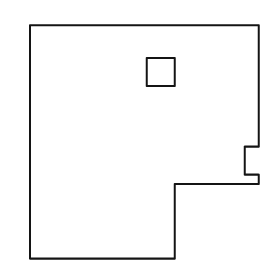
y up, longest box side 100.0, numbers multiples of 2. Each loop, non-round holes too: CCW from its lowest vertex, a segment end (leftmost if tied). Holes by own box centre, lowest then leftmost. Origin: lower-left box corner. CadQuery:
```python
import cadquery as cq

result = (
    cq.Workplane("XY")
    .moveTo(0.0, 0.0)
    .lineTo(62.0, 0.0)
    .lineTo(62.0, 32.0)
    .lineTo(98.0, 32.0)
    .lineTo(98.0, 36.0)
    .lineTo(92.0, 36.0)
    .lineTo(92.0, 48.0)
    .lineTo(98.0, 48.0)
    .lineTo(98.0, 100.0)
    .lineTo(0.0, 100.0)
    .close()
    .moveTo(50.0, 74.0)
    .lineTo(62.0, 74.0)
    .lineTo(62.0, 86.0)
    .lineTo(50.0, 86.0)
    .close()
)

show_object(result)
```